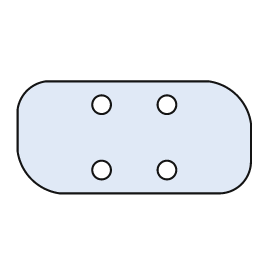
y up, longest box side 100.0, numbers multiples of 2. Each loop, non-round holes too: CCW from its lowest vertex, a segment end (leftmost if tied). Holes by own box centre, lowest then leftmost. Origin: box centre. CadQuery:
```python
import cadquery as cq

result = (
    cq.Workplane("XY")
    .moveTo(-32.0, -24.0)
    .lineTo(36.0, -24.0)
    .threePointArc((46.0, -20.0), (50.0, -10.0))
    .lineTo(50.0, 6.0)
    .threePointArc((44.0, 18.0), (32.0, 24.0))
    .lineTo(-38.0, 24.0)
    .threePointArc((-46.0, 20.0), (-50.0, 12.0))
    .lineTo(-50.0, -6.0)
    .threePointArc((-44.0, -18.0), (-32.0, -24.0))
    .close()
    .moveTo(-14.0, -14.0)
    .circle(4.0)
    .moveTo(14.0, -14.0)
    .circle(4.0)
    .moveTo(-14.0, 14.0)
    .circle(4.0)
    .moveTo(14.0, 14.0)
    .circle(4.0)
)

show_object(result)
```